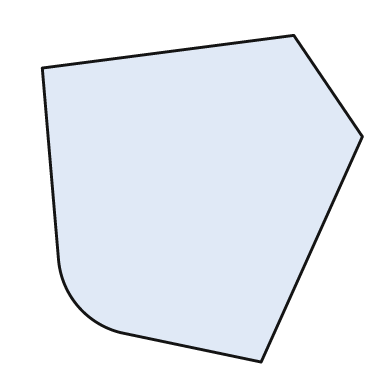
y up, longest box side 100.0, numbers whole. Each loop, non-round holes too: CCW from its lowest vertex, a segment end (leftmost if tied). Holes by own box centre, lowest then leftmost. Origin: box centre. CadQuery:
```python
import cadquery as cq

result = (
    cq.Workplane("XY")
    .moveTo(18.0, -50.0)
    .lineTo(49.0, 19.0)
    .lineTo(28.0, 50.0)
    .lineTo(-49.0, 40.0)
    .lineTo(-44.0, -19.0)
    .threePointArc((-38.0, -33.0), (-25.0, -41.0))
    .close()
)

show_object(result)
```